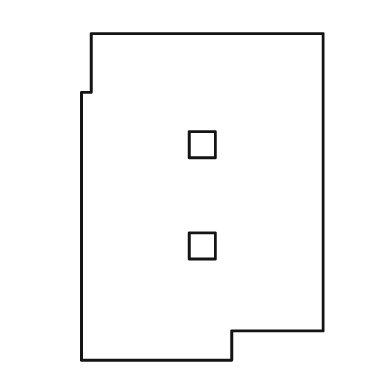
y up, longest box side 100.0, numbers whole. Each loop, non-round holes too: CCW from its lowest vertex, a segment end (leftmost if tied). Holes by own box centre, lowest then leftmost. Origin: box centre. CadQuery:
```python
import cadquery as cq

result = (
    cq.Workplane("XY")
    .moveTo(-37.0, -50.0)
    .lineTo(9.0, -50.0)
    .lineTo(9.0, -41.0)
    .lineTo(37.0, -41.0)
    .lineTo(37.0, 50.0)
    .lineTo(-34.0, 50.0)
    .lineTo(-34.0, 32.0)
    .lineTo(-37.0, 32.0)
    .close()
    .moveTo(-4.0, -19.0)
    .lineTo(4.0, -19.0)
    .lineTo(4.0, -11.0)
    .lineTo(-4.0, -11.0)
    .close()
    .moveTo(-4.0, 12.0)
    .lineTo(4.0, 12.0)
    .lineTo(4.0, 20.0)
    .lineTo(-4.0, 20.0)
    .close()
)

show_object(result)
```